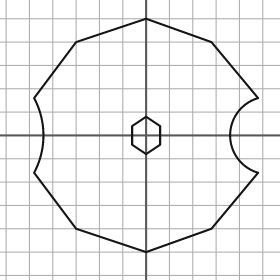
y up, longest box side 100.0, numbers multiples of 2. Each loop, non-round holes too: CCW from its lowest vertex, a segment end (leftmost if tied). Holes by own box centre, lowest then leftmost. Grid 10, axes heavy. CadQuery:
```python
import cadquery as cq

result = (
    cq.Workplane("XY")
    .moveTo(0.0, -50.0)
    .lineTo(28.0, -40.0)
    .lineTo(48.0, -16.0)
    .threePointArc((36.0, 0.0), (48.0, 16.0))
    .lineTo(28.0, 40.0)
    .lineTo(0.0, 50.0)
    .lineTo(-30.0, 40.0)
    .lineTo(-48.0, 16.0)
    .threePointArc((-44.0, 0.0), (-48.0, -16.0))
    .lineTo(-30.0, -40.0)
    .close()
    .moveTo(0.0, -8.0)
    .lineTo(6.0, -4.0)
    .lineTo(6.0, 4.0)
    .lineTo(0.0, 8.0)
    .lineTo(-6.0, 4.0)
    .lineTo(-6.0, -4.0)
    .close()
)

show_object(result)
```